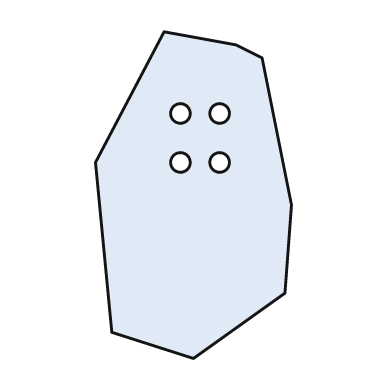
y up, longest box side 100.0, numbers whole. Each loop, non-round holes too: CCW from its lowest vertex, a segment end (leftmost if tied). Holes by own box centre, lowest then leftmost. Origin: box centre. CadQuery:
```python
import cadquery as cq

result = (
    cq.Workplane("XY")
    .moveTo(0.0, -50.0)
    .lineTo(28.0, -30.0)
    .lineTo(30.0, -3.0)
    .lineTo(21.0, 42.0)
    .lineTo(13.0, 46.0)
    .lineTo(-9.0, 50.0)
    .lineTo(-30.0, 10.0)
    .lineTo(-25.0, -42.0)
    .close()
    .moveTo(-4.0, 10.0)
    .circle(3.0)
    .moveTo(8.0, 10.0)
    .circle(3.0)
    .moveTo(-4.0, 25.0)
    .circle(3.0)
    .moveTo(8.0, 25.0)
    .circle(3.0)
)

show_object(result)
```